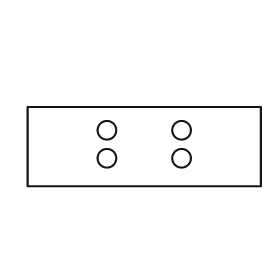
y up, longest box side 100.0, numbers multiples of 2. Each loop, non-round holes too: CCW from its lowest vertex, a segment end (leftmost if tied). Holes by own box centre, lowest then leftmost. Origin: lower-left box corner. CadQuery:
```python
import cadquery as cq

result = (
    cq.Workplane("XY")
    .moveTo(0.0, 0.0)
    .lineTo(100.0, 0.0)
    .lineTo(100.0, 34.0)
    .lineTo(0.0, 34.0)
    .close()
    .moveTo(34.0, 12.0)
    .circle(4.0)
    .moveTo(66.0, 12.0)
    .circle(4.0)
    .moveTo(34.0, 24.0)
    .circle(4.0)
    .moveTo(66.0, 24.0)
    .circle(4.0)
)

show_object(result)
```